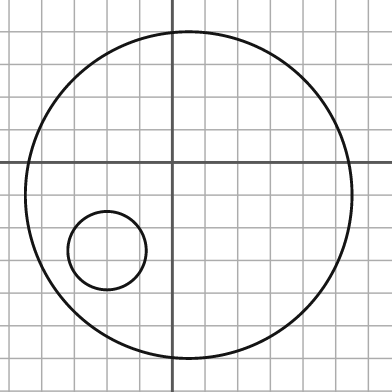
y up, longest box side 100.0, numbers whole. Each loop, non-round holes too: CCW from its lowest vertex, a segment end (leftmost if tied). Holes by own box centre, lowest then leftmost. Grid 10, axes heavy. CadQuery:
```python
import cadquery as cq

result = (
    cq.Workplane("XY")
    .moveTo(5.0, -10.0)
    .circle(50.0)
    .moveTo(-20.0, -27.0)
    .circle(12.0)
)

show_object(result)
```